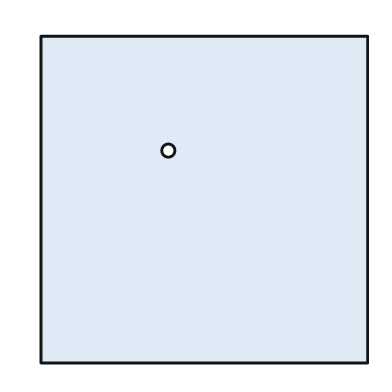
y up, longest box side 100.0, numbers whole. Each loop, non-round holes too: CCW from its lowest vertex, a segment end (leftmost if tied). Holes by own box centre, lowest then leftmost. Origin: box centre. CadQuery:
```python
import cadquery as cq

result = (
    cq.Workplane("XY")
    .moveTo(-50.0, -50.0)
    .lineTo(50.0, -50.0)
    .lineTo(50.0, 50.0)
    .lineTo(-50.0, 50.0)
    .close()
    .moveTo(-11.0, 15.0)
    .circle(2.0)
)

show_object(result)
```